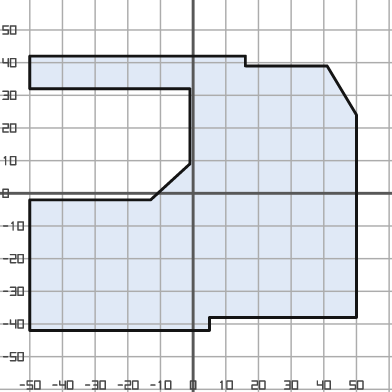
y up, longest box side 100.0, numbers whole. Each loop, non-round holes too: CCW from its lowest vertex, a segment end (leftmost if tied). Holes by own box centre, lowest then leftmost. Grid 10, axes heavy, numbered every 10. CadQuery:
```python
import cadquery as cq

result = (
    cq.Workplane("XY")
    .moveTo(-50.0, -42.0)
    .lineTo(5.0, -42.0)
    .lineTo(5.0, -38.0)
    .lineTo(50.0, -38.0)
    .lineTo(50.0, 24.0)
    .lineTo(41.0, 39.0)
    .lineTo(16.0, 39.0)
    .lineTo(16.0, 42.0)
    .lineTo(-50.0, 42.0)
    .lineTo(-50.0, 32.0)
    .lineTo(-1.0, 32.0)
    .lineTo(-1.0, 9.0)
    .lineTo(-13.0, -2.0)
    .lineTo(-50.0, -2.0)
    .close()
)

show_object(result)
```